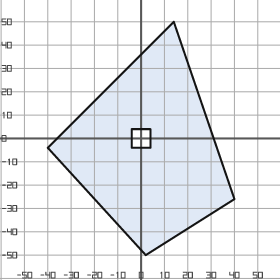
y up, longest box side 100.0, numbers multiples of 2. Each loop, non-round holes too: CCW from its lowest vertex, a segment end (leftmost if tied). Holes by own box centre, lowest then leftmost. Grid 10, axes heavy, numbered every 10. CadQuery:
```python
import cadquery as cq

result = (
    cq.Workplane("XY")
    .moveTo(2.0, -50.0)
    .lineTo(40.0, -26.0)
    .lineTo(14.0, 50.0)
    .lineTo(-40.0, -4.0)
    .close()
    .moveTo(-4.0, -4.0)
    .lineTo(4.0, -4.0)
    .lineTo(4.0, 4.0)
    .lineTo(-4.0, 4.0)
    .close()
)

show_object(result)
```